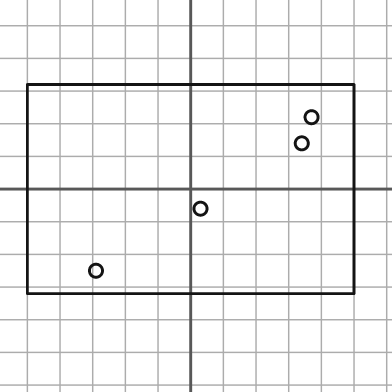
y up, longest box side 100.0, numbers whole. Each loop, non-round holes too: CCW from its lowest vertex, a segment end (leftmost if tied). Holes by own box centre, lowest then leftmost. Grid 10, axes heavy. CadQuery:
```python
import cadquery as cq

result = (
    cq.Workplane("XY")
    .moveTo(-50.0, -32.0)
    .lineTo(50.0, -32.0)
    .lineTo(50.0, 32.0)
    .lineTo(-50.0, 32.0)
    .close()
    .moveTo(-29.0, -25.0)
    .circle(2.0)
    .moveTo(3.0, -6.0)
    .circle(2.0)
    .moveTo(34.0, 14.0)
    .circle(2.0)
    .moveTo(37.0, 22.0)
    .circle(2.0)
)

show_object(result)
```